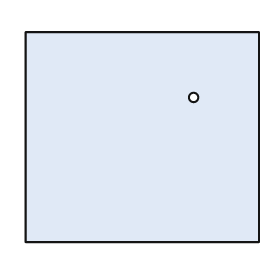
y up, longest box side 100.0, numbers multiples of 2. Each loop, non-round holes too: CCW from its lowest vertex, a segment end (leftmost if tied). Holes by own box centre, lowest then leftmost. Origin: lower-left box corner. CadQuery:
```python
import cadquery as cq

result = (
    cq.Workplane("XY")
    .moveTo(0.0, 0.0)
    .lineTo(100.0, 0.0)
    .lineTo(100.0, 90.0)
    .lineTo(0.0, 90.0)
    .close()
    .moveTo(72.0, 62.0)
    .circle(2.0)
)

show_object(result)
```